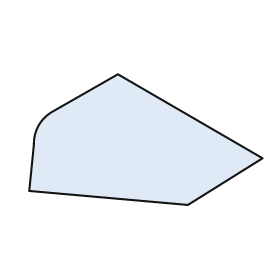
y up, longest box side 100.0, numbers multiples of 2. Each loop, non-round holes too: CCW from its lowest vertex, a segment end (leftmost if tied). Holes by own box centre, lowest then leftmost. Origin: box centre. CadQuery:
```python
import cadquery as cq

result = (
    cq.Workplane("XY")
    .moveTo(18.0, -28.0)
    .lineTo(50.0, -8.0)
    .lineTo(-12.0, 28.0)
    .lineTo(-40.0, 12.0)
    .threePointArc((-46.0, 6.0), (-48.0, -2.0))
    .lineTo(-50.0, -22.0)
    .close()
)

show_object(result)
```